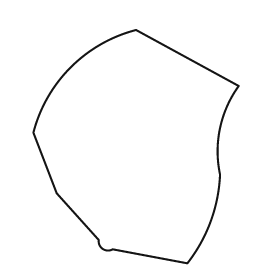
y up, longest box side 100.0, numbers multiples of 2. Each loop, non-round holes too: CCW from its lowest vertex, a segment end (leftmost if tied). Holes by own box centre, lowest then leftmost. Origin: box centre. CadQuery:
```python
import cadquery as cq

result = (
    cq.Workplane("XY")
    .moveTo(22.0, -50.0)
    .threePointArc((32.0, -32.0), (36.0, -12.0))
    .threePointArc((36.0, 8.0), (44.0, 26.0))
    .lineTo(0.0, 50.0)
    .threePointArc((-28.0, 34.0), (-44.0, 6.0))
    .lineTo(-34.0, -20.0)
    .lineTo(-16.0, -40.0)
    .threePointArc((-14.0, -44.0), (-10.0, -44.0))
    .close()
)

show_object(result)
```